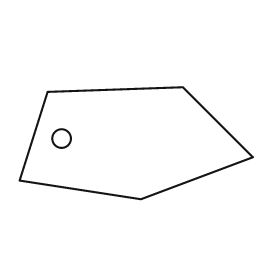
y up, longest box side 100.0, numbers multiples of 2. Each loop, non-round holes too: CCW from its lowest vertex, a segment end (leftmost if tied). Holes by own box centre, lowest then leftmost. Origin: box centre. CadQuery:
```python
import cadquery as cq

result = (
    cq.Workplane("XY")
    .moveTo(2.0, -24.0)
    .lineTo(50.0, -6.0)
    .lineTo(20.0, 24.0)
    .lineTo(-38.0, 22.0)
    .lineTo(-50.0, -16.0)
    .close()
    .moveTo(-32.0, 2.0)
    .circle(4.0)
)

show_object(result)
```